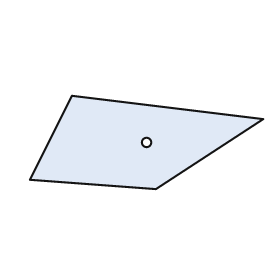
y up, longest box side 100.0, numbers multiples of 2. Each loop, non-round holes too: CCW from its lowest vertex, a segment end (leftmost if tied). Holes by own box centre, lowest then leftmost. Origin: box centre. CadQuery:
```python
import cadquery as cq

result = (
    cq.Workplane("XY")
    .moveTo(4.0, -20.0)
    .lineTo(50.0, 10.0)
    .lineTo(-32.0, 20.0)
    .lineTo(-50.0, -16.0)
    .close()
    .moveTo(0.0, 0.0)
    .circle(2.0)
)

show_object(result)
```